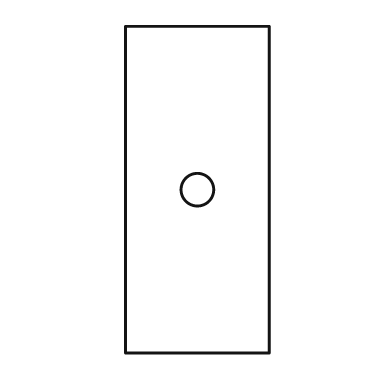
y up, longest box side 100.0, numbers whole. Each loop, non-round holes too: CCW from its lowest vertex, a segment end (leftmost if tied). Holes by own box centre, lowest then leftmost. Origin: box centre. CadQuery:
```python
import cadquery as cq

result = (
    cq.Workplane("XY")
    .moveTo(-22.0, -50.0)
    .lineTo(22.0, -50.0)
    .lineTo(22.0, 50.0)
    .lineTo(-22.0, 50.0)
    .close()
    .moveTo(0.0, 0.0)
    .circle(5.0)
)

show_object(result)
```